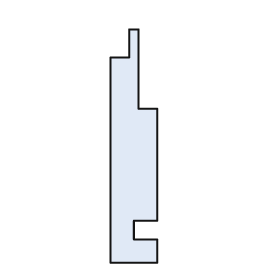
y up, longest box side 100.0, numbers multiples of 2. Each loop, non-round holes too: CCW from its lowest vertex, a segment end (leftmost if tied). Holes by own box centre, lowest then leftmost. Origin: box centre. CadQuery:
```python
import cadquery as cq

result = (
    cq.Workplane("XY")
    .moveTo(-10.0, -50.0)
    .lineTo(10.0, -50.0)
    .lineTo(10.0, -40.0)
    .lineTo(0.0, -40.0)
    .lineTo(0.0, -32.0)
    .lineTo(10.0, -32.0)
    .lineTo(10.0, 16.0)
    .lineTo(2.0, 16.0)
    .lineTo(2.0, 50.0)
    .lineTo(-2.0, 50.0)
    .lineTo(-2.0, 38.0)
    .lineTo(-10.0, 38.0)
    .close()
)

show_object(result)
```